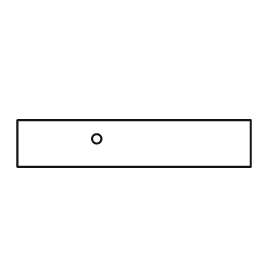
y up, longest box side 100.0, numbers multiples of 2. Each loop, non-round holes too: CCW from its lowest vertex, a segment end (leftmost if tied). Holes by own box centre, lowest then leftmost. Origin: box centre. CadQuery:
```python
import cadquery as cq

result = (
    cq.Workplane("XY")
    .moveTo(-50.0, -10.0)
    .lineTo(50.0, -10.0)
    .lineTo(50.0, 10.0)
    .lineTo(-50.0, 10.0)
    .close()
    .moveTo(-16.0, 2.0)
    .circle(2.0)
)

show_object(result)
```